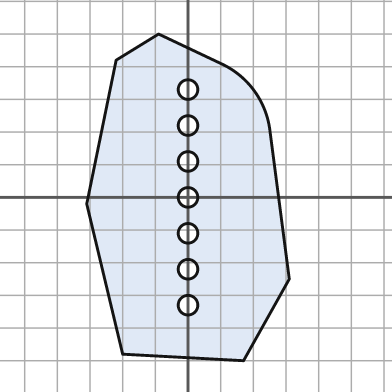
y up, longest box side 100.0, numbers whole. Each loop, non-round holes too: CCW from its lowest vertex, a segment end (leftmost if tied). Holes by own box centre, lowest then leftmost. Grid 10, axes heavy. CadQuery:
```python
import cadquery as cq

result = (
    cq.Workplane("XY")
    .moveTo(17.0, -50.0)
    .lineTo(31.0, -25.0)
    .lineTo(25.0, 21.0)
    .threePointArc((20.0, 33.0), (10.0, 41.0))
    .lineTo(-9.0, 50.0)
    .lineTo(-22.0, 42.0)
    .lineTo(-31.0, -2.0)
    .lineTo(-20.0, -48.0)
    .close()
    .moveTo(0.0, -33.0)
    .circle(3.0)
    .moveTo(0.0, -22.0)
    .circle(3.0)
    .moveTo(0.0, -11.0)
    .circle(3.0)
    .moveTo(0.0, 0.0)
    .circle(3.0)
    .moveTo(0.0, 11.0)
    .circle(3.0)
    .moveTo(0.0, 22.0)
    .circle(3.0)
    .moveTo(0.0, 33.0)
    .circle(3.0)
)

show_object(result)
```